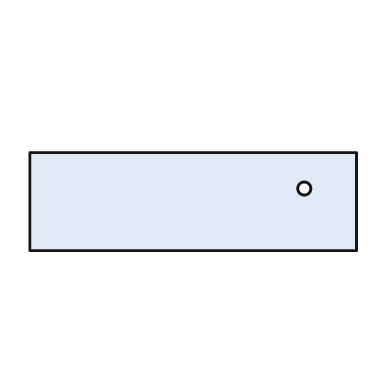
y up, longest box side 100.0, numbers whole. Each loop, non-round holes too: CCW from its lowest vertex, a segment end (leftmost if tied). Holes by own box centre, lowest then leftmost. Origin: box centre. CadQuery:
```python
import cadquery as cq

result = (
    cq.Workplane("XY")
    .moveTo(-50.0, -15.0)
    .lineTo(50.0, -15.0)
    .lineTo(50.0, 15.0)
    .lineTo(-50.0, 15.0)
    .close()
    .moveTo(34.0, 4.0)
    .circle(2.0)
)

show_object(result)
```